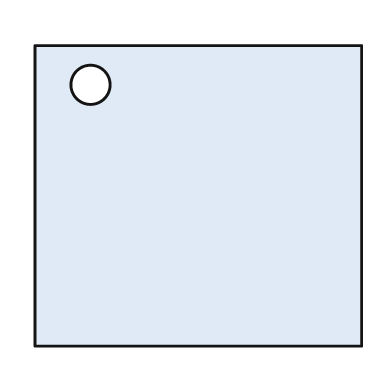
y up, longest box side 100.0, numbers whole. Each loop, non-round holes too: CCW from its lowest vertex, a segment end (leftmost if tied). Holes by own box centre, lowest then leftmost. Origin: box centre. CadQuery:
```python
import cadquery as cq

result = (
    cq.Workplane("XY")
    .moveTo(-50.0, -46.0)
    .lineTo(50.0, -46.0)
    .lineTo(50.0, 46.0)
    .lineTo(-50.0, 46.0)
    .close()
    .moveTo(-33.0, 34.0)
    .circle(6.0)
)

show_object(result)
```